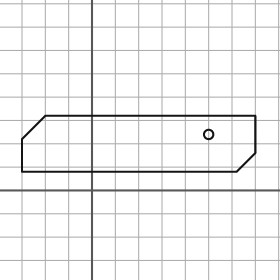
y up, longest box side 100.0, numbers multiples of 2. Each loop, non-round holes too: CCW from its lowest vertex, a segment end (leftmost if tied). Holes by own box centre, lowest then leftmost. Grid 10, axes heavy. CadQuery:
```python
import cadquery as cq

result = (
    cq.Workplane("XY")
    .moveTo(-30.0, 8.0)
    .lineTo(62.0, 8.0)
    .lineTo(70.0, 16.0)
    .lineTo(70.0, 32.0)
    .lineTo(-20.0, 32.0)
    .lineTo(-30.0, 22.0)
    .close()
    .moveTo(50.0, 24.0)
    .circle(2.0)
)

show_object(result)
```